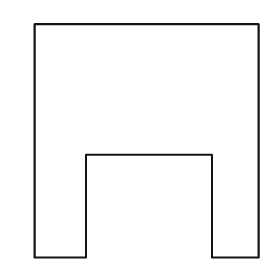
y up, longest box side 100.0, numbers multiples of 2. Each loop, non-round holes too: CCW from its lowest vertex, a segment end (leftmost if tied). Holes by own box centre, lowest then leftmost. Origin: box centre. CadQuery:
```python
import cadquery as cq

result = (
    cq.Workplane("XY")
    .moveTo(-48.0, -50.0)
    .lineTo(-26.0, -50.0)
    .lineTo(-26.0, -6.0)
    .lineTo(28.0, -6.0)
    .lineTo(28.0, -50.0)
    .lineTo(48.0, -50.0)
    .lineTo(48.0, 50.0)
    .lineTo(-48.0, 50.0)
    .close()
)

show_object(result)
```